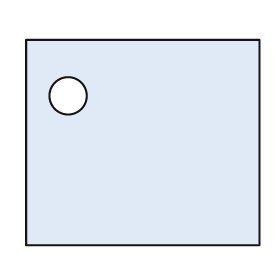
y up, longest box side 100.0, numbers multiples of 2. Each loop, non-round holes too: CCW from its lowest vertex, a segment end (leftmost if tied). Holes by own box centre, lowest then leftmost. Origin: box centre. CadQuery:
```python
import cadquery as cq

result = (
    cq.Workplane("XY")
    .moveTo(-50.0, -44.0)
    .lineTo(50.0, -44.0)
    .lineTo(50.0, 44.0)
    .lineTo(-50.0, 44.0)
    .close()
    .moveTo(-32.0, 20.0)
    .circle(8.0)
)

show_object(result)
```